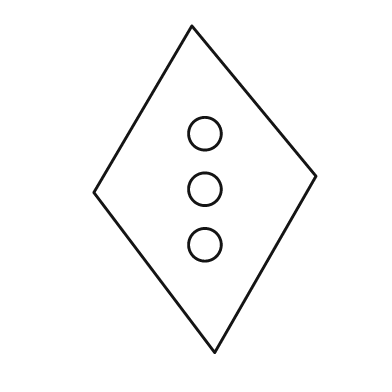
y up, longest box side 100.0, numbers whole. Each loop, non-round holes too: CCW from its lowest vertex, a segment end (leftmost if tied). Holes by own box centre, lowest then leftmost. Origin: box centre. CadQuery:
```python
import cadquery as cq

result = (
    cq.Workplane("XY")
    .moveTo(3.0, -50.0)
    .lineTo(34.0, 4.0)
    .lineTo(-4.0, 50.0)
    .lineTo(-34.0, -1.0)
    .close()
    .moveTo(0.0, -17.0)
    .circle(5.0)
    .moveTo(0.0, 0.0)
    .circle(5.0)
    .moveTo(0.0, 17.0)
    .circle(5.0)
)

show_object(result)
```